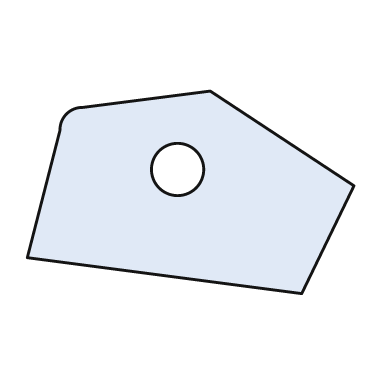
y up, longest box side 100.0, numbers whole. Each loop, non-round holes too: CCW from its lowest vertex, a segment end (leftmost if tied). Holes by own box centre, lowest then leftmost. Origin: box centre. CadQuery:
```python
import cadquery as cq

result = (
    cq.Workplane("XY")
    .moveTo(34.0, -31.0)
    .lineTo(50.0, 2.0)
    .lineTo(6.0, 31.0)
    .lineTo(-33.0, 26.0)
    .threePointArc((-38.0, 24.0), (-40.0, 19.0))
    .lineTo(-50.0, -20.0)
    .close()
    .moveTo(-4.0, 7.0)
    .circle(8.0)
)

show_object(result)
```